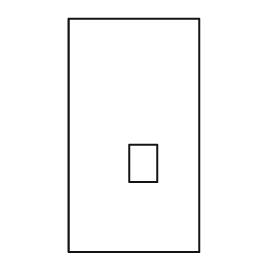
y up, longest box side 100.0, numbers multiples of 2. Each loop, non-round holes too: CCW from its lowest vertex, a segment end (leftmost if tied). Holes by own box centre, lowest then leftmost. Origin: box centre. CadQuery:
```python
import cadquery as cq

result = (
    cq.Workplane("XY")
    .moveTo(-28.0, -50.0)
    .lineTo(28.0, -50.0)
    .lineTo(28.0, 50.0)
    .lineTo(-28.0, 50.0)
    .close()
    .moveTo(-2.0, -20.0)
    .lineTo(10.0, -20.0)
    .lineTo(10.0, -4.0)
    .lineTo(-2.0, -4.0)
    .close()
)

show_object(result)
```